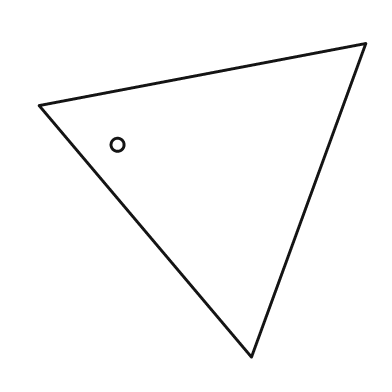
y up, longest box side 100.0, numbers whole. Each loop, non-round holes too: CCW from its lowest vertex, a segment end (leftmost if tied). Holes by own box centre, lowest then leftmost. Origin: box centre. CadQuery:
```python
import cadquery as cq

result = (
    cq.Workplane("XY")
    .moveTo(15.0, -48.0)
    .lineTo(50.0, 48.0)
    .lineTo(-50.0, 29.0)
    .close()
    .moveTo(-26.0, 17.0)
    .circle(2.0)
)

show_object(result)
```